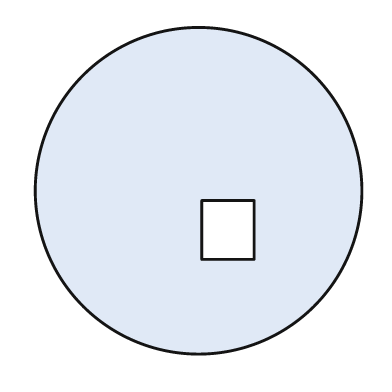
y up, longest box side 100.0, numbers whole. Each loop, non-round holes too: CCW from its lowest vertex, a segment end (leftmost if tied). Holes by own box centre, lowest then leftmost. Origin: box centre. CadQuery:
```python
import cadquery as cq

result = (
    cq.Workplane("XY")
    .moveTo(0.0, 0.0)
    .circle(50.0)
    .moveTo(1.0, -21.0)
    .lineTo(17.0, -21.0)
    .lineTo(17.0, -3.0)
    .lineTo(1.0, -3.0)
    .close()
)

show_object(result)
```